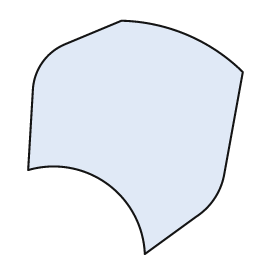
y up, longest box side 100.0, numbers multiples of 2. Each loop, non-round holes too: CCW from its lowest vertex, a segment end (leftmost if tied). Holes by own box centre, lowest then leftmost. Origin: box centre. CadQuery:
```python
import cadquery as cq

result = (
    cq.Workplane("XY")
    .moveTo(4.0, -50.0)
    .lineTo(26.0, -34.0)
    .threePointArc((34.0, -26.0), (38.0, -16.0))
    .lineTo(46.0, 28.0)
    .threePointArc((22.0, 44.0), (-6.0, 50.0))
    .lineTo(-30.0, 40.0)
    .threePointArc((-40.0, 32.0), (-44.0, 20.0))
    .lineTo(-46.0, -14.0)
    .threePointArc((-12.0, -20.0), (4.0, -50.0))
    .close()
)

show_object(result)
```